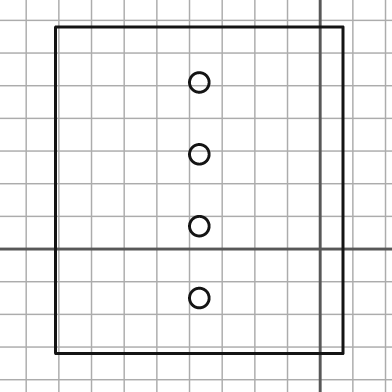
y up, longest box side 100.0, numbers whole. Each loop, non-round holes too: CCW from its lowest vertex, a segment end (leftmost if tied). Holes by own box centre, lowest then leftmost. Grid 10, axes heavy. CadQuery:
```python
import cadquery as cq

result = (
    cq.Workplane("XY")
    .moveTo(-81.0, -32.0)
    .lineTo(7.0, -32.0)
    .lineTo(7.0, 68.0)
    .lineTo(-81.0, 68.0)
    .close()
    .moveTo(-37.0, -15.0)
    .circle(3.0)
    .moveTo(-37.0, 7.0)
    .circle(3.0)
    .moveTo(-37.0, 29.0)
    .circle(3.0)
    .moveTo(-37.0, 51.0)
    .circle(3.0)
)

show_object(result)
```